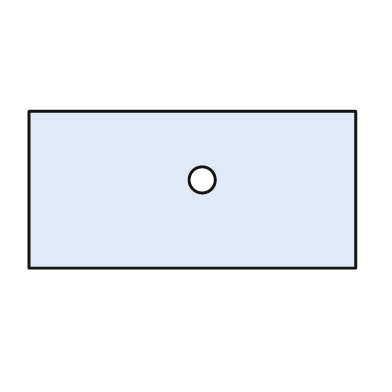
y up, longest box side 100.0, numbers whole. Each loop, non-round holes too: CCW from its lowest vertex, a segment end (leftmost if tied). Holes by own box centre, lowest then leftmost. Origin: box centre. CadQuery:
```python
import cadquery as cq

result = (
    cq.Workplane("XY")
    .moveTo(-50.0, -24.0)
    .lineTo(50.0, -24.0)
    .lineTo(50.0, 24.0)
    .lineTo(-50.0, 24.0)
    .close()
    .moveTo(3.0, 3.0)
    .circle(4.0)
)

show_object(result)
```